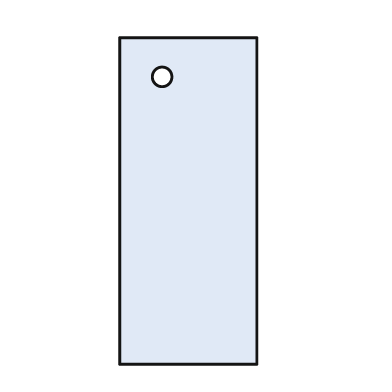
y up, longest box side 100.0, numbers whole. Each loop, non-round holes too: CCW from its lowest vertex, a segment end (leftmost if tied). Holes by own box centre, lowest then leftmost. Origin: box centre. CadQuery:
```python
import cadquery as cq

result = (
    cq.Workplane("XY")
    .moveTo(-21.0, -50.0)
    .lineTo(21.0, -50.0)
    .lineTo(21.0, 50.0)
    .lineTo(-21.0, 50.0)
    .close()
    .moveTo(-8.0, 38.0)
    .circle(3.0)
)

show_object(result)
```